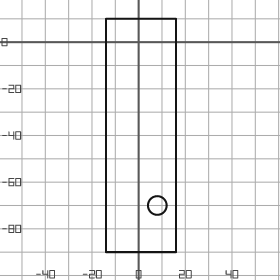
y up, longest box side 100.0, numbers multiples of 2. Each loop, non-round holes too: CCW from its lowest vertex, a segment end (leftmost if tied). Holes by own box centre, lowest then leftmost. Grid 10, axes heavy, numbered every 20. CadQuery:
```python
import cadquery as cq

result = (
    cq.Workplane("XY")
    .moveTo(-14.0, -90.0)
    .lineTo(16.0, -90.0)
    .lineTo(16.0, 10.0)
    .lineTo(-14.0, 10.0)
    .close()
    .moveTo(8.0, -70.0)
    .circle(4.0)
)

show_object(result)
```